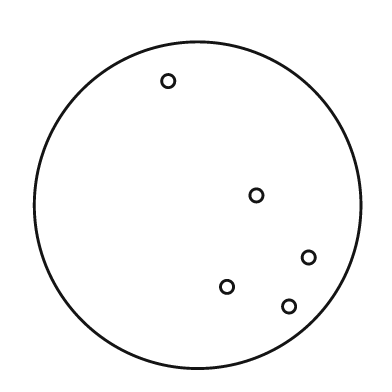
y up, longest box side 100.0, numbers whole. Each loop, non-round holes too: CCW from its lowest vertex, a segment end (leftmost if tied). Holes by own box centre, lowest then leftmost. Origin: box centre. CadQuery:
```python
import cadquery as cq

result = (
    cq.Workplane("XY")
    .moveTo(0.0, 0.0)
    .circle(50.0)
    .moveTo(28.0, -31.0)
    .circle(2.0)
    .moveTo(9.0, -25.0)
    .circle(2.0)
    .moveTo(34.0, -16.0)
    .circle(2.0)
    .moveTo(18.0, 3.0)
    .circle(2.0)
    .moveTo(-9.0, 38.0)
    .circle(2.0)
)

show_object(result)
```